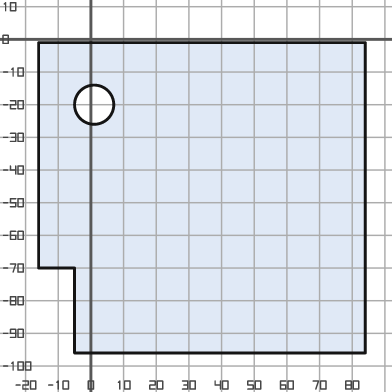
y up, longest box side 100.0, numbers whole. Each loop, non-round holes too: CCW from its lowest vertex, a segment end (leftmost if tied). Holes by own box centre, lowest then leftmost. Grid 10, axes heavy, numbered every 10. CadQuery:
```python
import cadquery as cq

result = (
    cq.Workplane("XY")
    .moveTo(-5.0, -96.0)
    .lineTo(84.0, -96.0)
    .lineTo(84.0, -1.0)
    .lineTo(-16.0, -1.0)
    .lineTo(-16.0, -70.0)
    .lineTo(-5.0, -70.0)
    .close()
    .moveTo(1.0, -20.0)
    .circle(6.0)
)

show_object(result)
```